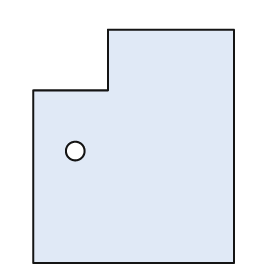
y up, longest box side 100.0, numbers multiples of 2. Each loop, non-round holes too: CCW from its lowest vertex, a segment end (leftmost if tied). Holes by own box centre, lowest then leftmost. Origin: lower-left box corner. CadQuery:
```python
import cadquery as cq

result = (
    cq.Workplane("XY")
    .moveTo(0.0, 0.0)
    .lineTo(86.0, 0.0)
    .lineTo(86.0, 100.0)
    .lineTo(32.0, 100.0)
    .lineTo(32.0, 74.0)
    .lineTo(0.0, 74.0)
    .close()
    .moveTo(18.0, 48.0)
    .circle(4.0)
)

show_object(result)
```